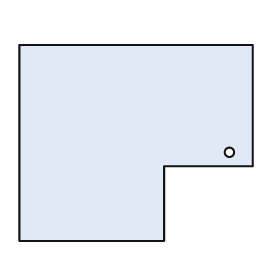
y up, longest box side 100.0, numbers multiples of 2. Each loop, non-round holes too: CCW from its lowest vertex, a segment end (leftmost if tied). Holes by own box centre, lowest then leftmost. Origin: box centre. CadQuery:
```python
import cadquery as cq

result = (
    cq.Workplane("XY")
    .moveTo(-50.0, -42.0)
    .lineTo(12.0, -42.0)
    .lineTo(12.0, -10.0)
    .lineTo(50.0, -10.0)
    .lineTo(50.0, 42.0)
    .lineTo(-50.0, 42.0)
    .close()
    .moveTo(40.0, -4.0)
    .circle(2.0)
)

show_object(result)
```